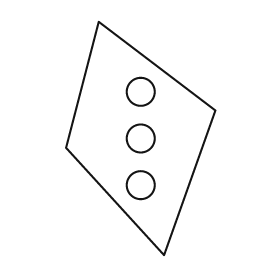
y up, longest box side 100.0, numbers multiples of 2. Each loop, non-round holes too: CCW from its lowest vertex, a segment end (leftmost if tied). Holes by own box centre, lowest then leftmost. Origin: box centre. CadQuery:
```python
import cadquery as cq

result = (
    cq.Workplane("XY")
    .moveTo(10.0, -50.0)
    .lineTo(32.0, 12.0)
    .lineTo(-18.0, 50.0)
    .lineTo(-32.0, -4.0)
    .close()
    .moveTo(0.0, -20.0)
    .circle(6.0)
    .moveTo(0.0, 0.0)
    .circle(6.0)
    .moveTo(0.0, 20.0)
    .circle(6.0)
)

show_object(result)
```